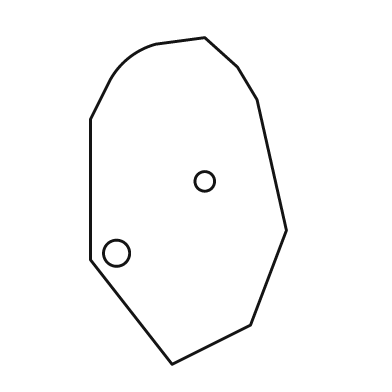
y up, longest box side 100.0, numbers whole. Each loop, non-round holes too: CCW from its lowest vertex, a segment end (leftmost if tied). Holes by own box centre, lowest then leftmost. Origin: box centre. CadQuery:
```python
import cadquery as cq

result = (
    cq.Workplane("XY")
    .moveTo(-5.0, -50.0)
    .lineTo(19.0, -38.0)
    .lineTo(30.0, -9.0)
    .lineTo(21.0, 31.0)
    .lineTo(15.0, 41.0)
    .lineTo(5.0, 50.0)
    .lineTo(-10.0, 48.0)
    .threePointArc((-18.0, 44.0), (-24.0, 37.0))
    .lineTo(-30.0, 25.0)
    .lineTo(-30.0, -18.0)
    .close()
    .moveTo(-22.0, -16.0)
    .circle(4.0)
    .moveTo(5.0, 6.0)
    .circle(3.0)
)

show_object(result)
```